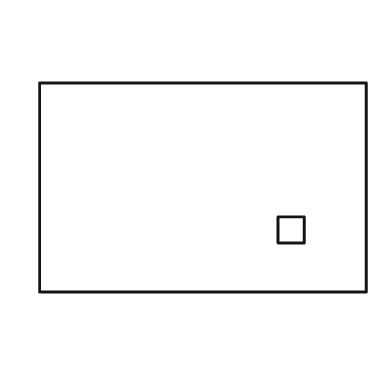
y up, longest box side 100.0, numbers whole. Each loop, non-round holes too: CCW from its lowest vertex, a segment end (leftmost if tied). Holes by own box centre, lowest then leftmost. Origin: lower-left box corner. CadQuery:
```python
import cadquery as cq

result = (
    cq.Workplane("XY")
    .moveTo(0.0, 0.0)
    .lineTo(100.0, 0.0)
    .lineTo(100.0, 64.0)
    .lineTo(0.0, 64.0)
    .close()
    .moveTo(73.0, 15.0)
    .lineTo(81.0, 15.0)
    .lineTo(81.0, 23.0)
    .lineTo(73.0, 23.0)
    .close()
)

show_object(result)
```